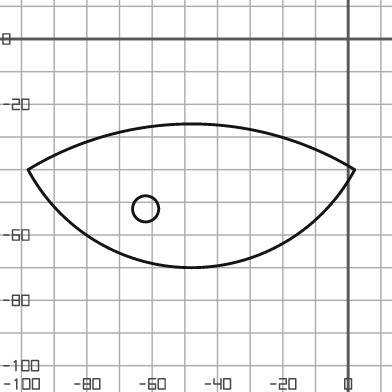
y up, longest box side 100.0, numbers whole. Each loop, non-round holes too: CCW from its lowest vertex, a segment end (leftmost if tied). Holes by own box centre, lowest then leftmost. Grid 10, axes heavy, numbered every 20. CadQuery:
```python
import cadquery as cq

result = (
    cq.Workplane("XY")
    .moveTo(-98.0, -40.0)
    .threePointArc((-48.0, -70.0), (2.0, -40.0))
    .threePointArc((-48.0, -26.0), (-98.0, -40.0))
    .close()
    .moveTo(-62.0, -52.0)
    .circle(4.0)
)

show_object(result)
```